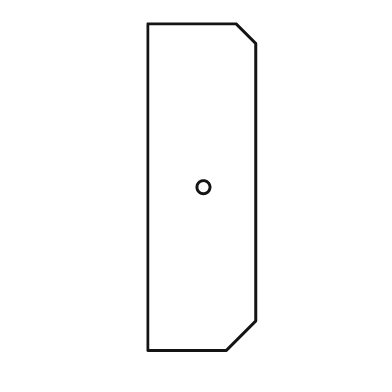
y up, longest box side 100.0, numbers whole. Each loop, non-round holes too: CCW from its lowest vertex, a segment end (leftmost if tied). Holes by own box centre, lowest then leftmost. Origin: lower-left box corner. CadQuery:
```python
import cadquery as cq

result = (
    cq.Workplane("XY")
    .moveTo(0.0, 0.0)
    .lineTo(24.0, 0.0)
    .lineTo(33.0, 9.0)
    .lineTo(33.0, 94.0)
    .lineTo(27.0, 100.0)
    .lineTo(0.0, 100.0)
    .close()
    .moveTo(17.0, 50.0)
    .circle(2.0)
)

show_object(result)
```